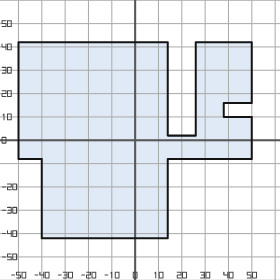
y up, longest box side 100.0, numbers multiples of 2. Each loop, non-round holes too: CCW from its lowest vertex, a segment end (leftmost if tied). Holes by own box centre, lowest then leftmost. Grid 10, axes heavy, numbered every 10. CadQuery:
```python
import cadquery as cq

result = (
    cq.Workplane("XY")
    .moveTo(-40.0, -42.0)
    .lineTo(14.0, -42.0)
    .lineTo(14.0, -8.0)
    .lineTo(50.0, -8.0)
    .lineTo(50.0, 10.0)
    .lineTo(38.0, 10.0)
    .lineTo(38.0, 16.0)
    .lineTo(50.0, 16.0)
    .lineTo(50.0, 42.0)
    .lineTo(26.0, 42.0)
    .lineTo(26.0, 2.0)
    .lineTo(14.0, 2.0)
    .lineTo(14.0, 42.0)
    .lineTo(-50.0, 42.0)
    .lineTo(-50.0, -8.0)
    .lineTo(-40.0, -8.0)
    .close()
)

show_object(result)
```